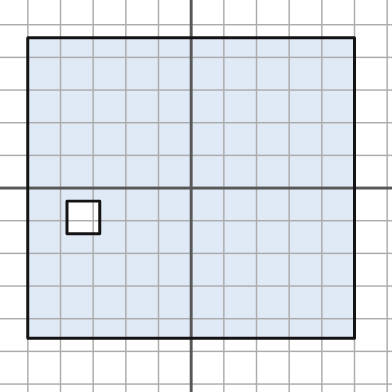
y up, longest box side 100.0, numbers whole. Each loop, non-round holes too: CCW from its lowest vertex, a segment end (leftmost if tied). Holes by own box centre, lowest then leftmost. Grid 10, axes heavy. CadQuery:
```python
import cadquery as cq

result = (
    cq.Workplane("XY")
    .moveTo(-50.0, -46.0)
    .lineTo(50.0, -46.0)
    .lineTo(50.0, 46.0)
    .lineTo(-50.0, 46.0)
    .close()
    .moveTo(-38.0, -14.0)
    .lineTo(-28.0, -14.0)
    .lineTo(-28.0, -4.0)
    .lineTo(-38.0, -4.0)
    .close()
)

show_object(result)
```